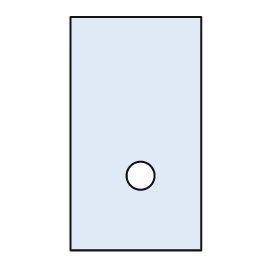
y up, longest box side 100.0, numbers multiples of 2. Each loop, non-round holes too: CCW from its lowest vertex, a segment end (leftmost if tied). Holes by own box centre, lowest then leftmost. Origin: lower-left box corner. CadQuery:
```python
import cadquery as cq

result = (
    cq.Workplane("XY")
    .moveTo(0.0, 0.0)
    .lineTo(56.0, 0.0)
    .lineTo(56.0, 100.0)
    .lineTo(0.0, 100.0)
    .close()
    .moveTo(30.0, 32.0)
    .circle(6.0)
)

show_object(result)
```